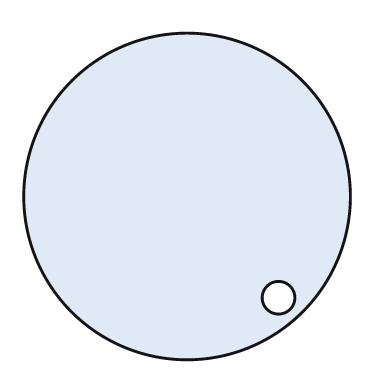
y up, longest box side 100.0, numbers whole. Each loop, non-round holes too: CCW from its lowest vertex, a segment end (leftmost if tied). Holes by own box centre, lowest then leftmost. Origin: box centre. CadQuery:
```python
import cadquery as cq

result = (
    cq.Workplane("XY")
    .moveTo(0.0, 0.0)
    .circle(50.0)
    .moveTo(28.0, -31.0)
    .circle(5.0)
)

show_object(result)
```